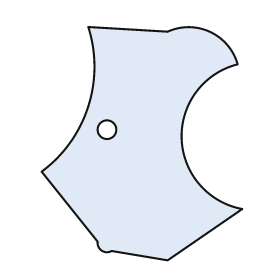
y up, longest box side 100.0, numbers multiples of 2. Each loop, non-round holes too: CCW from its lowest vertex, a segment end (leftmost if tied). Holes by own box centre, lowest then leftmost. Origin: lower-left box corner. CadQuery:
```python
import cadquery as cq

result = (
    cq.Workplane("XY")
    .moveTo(54.0, 0.0)
    .lineTo(86.0, 22.0)
    .threePointArc((60.0, 52.0), (84.0, 84.0))
    .threePointArc((72.0, 98.0), (54.0, 98.0))
    .lineTo(20.0, 100.0)
    .threePointArc((20.0, 66.0), (0.0, 38.0))
    .lineTo(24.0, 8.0)
    .threePointArc((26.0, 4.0), (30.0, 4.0))
    .close()
    .moveTo(28.0, 56.0)
    .circle(4.0)
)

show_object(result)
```